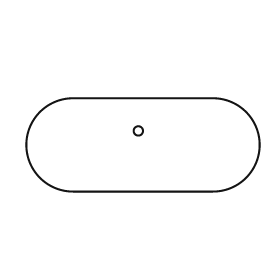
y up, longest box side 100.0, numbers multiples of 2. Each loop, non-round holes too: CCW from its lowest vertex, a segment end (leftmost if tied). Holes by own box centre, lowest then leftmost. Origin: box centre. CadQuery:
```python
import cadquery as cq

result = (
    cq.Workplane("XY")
    .moveTo(-30.0, -20.0)
    .lineTo(30.0, -20.0)
    .threePointArc((50.0, 0.0), (30.0, 20.0))
    .lineTo(-30.0, 20.0)
    .threePointArc((-50.0, 0.0), (-30.0, -20.0))
    .close()
    .moveTo(-2.0, 6.0)
    .circle(2.0)
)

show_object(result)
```